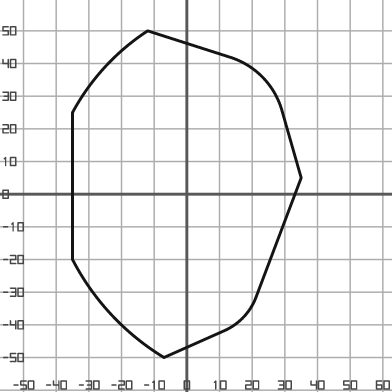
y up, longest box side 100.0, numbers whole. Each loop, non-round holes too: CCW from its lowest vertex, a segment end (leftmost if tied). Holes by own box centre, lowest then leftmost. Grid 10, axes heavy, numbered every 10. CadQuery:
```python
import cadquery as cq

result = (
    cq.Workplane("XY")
    .moveTo(-7.0, -50.0)
    .lineTo(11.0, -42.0)
    .threePointArc((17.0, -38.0), (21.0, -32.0))
    .lineTo(35.0, 5.0)
    .lineTo(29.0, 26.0)
    .threePointArc((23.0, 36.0), (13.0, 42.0))
    .lineTo(-12.0, 50.0)
    .threePointArc((-25.0, 39.0), (-35.0, 25.0))
    .lineTo(-35.0, -20.0)
    .threePointArc((-23.0, -37.0), (-7.0, -50.0))
    .close()
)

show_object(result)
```